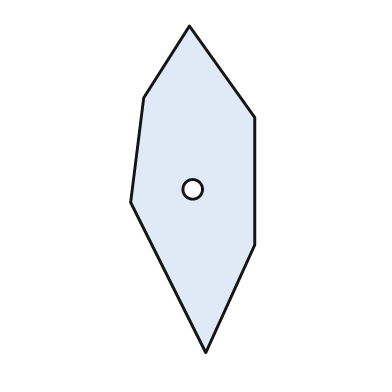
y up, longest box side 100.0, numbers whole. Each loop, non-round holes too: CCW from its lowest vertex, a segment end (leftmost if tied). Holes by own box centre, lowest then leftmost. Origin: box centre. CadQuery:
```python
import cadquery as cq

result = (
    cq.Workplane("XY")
    .moveTo(4.0, -50.0)
    .lineTo(19.0, -17.0)
    .lineTo(19.0, 22.0)
    .lineTo(-1.0, 50.0)
    .lineTo(-15.0, 28.0)
    .lineTo(-19.0, -4.0)
    .close()
    .moveTo(0.0, 0.0)
    .circle(3.0)
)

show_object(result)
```